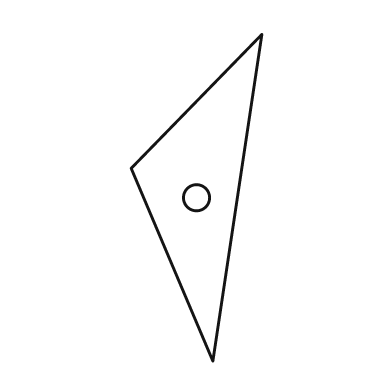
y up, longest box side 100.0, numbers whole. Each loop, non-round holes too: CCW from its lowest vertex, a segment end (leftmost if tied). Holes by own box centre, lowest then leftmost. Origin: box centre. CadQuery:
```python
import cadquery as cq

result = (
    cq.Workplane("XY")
    .moveTo(5.0, -50.0)
    .lineTo(20.0, 50.0)
    .lineTo(-20.0, 9.0)
    .close()
    .moveTo(0.0, 0.0)
    .circle(4.0)
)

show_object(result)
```